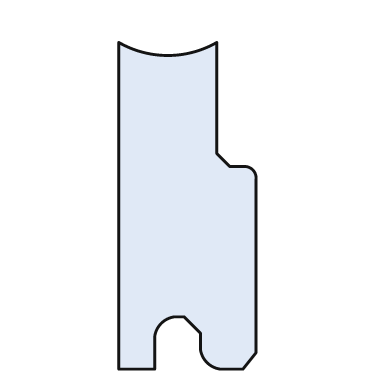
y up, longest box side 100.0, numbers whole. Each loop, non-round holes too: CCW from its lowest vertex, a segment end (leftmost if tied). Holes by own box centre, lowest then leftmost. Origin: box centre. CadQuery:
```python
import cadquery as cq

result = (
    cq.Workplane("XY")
    .moveTo(-21.0, -50.0)
    .lineTo(-10.0, -50.0)
    .lineTo(-10.0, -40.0)
    .threePointArc((-8.0, -36.0), (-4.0, -34.0))
    .lineTo(-1.0, -34.0)
    .lineTo(4.0, -39.0)
    .lineTo(4.0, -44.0)
    .threePointArc((6.0, -48.0), (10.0, -50.0))
    .lineTo(17.0, -50.0)
    .lineTo(21.0, -45.0)
    .lineTo(21.0, 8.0)
    .threePointArc((20.0, 11.0), (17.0, 12.0))
    .lineTo(13.0, 12.0)
    .lineTo(9.0, 16.0)
    .lineTo(9.0, 50.0)
    .threePointArc((-6.0, 46.0), (-21.0, 50.0))
    .close()
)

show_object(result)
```